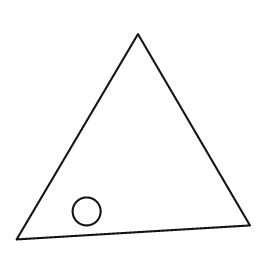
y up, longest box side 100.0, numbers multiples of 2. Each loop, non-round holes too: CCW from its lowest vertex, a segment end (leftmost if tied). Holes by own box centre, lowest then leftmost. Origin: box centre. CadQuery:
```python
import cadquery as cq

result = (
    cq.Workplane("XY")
    .moveTo(-50.0, -44.0)
    .lineTo(50.0, -38.0)
    .lineTo(2.0, 44.0)
    .close()
    .moveTo(-20.0, -32.0)
    .circle(6.0)
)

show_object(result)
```